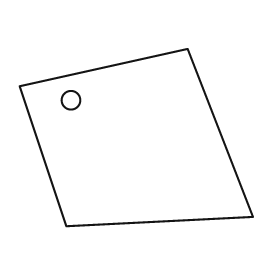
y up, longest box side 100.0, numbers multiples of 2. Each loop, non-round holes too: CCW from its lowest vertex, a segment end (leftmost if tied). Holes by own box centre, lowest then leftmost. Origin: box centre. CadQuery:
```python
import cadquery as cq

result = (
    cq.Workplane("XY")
    .moveTo(-30.0, -38.0)
    .lineTo(50.0, -34.0)
    .lineTo(22.0, 38.0)
    .lineTo(-50.0, 22.0)
    .close()
    .moveTo(-28.0, 16.0)
    .circle(4.0)
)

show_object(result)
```